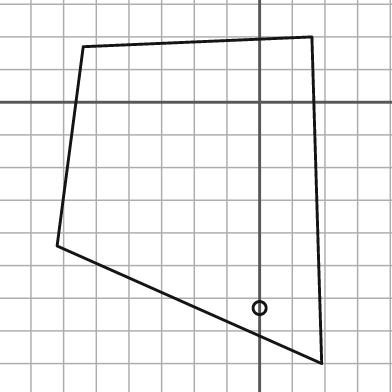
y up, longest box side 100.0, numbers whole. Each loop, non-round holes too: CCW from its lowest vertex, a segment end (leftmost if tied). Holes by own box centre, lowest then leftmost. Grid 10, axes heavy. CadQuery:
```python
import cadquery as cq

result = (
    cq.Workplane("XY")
    .moveTo(19.0, -80.0)
    .lineTo(16.0, 20.0)
    .lineTo(-54.0, 17.0)
    .lineTo(-62.0, -44.0)
    .close()
    .moveTo(0.0, -63.0)
    .circle(2.0)
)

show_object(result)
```